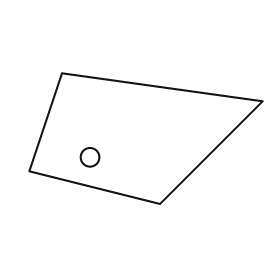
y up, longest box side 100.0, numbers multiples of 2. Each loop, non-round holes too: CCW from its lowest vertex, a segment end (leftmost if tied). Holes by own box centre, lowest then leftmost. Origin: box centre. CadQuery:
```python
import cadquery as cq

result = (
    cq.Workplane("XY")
    .moveTo(6.0, -28.0)
    .lineTo(50.0, 16.0)
    .lineTo(-36.0, 28.0)
    .lineTo(-50.0, -14.0)
    .close()
    .moveTo(-24.0, -8.0)
    .circle(4.0)
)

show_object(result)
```